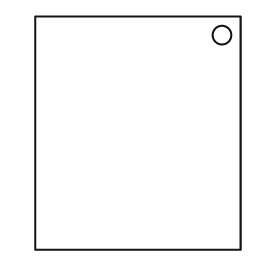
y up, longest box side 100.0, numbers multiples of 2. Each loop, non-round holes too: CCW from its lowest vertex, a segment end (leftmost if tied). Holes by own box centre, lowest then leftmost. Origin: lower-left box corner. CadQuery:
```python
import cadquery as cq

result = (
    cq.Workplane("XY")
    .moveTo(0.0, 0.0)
    .lineTo(88.0, 0.0)
    .lineTo(88.0, 100.0)
    .lineTo(0.0, 100.0)
    .close()
    .moveTo(80.0, 92.0)
    .circle(4.0)
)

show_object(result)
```